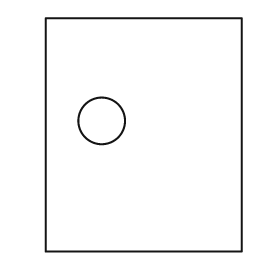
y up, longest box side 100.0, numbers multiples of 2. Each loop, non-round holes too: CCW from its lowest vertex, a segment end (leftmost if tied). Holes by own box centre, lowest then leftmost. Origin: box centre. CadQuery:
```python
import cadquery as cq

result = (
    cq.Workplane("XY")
    .moveTo(-42.0, -50.0)
    .lineTo(42.0, -50.0)
    .lineTo(42.0, 50.0)
    .lineTo(-42.0, 50.0)
    .close()
    .moveTo(-18.0, 6.0)
    .circle(10.0)
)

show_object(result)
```